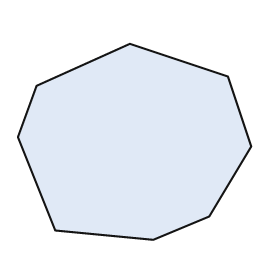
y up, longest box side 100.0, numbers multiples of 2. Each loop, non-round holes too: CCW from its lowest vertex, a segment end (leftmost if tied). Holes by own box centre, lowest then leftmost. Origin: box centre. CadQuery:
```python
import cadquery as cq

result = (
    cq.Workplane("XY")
    .moveTo(8.0, -42.0)
    .lineTo(32.0, -32.0)
    .lineTo(50.0, -2.0)
    .lineTo(40.0, 28.0)
    .lineTo(-2.0, 42.0)
    .lineTo(-42.0, 24.0)
    .lineTo(-50.0, 2.0)
    .lineTo(-34.0, -38.0)
    .close()
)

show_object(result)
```